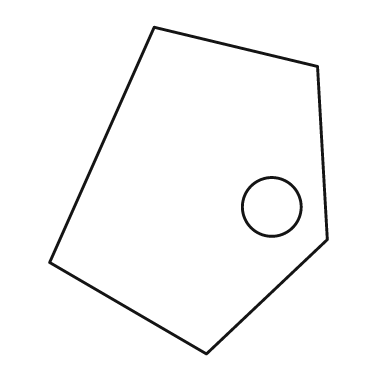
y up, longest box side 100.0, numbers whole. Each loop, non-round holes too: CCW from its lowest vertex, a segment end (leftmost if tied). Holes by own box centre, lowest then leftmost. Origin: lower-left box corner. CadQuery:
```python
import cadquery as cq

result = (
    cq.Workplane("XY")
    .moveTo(48.0, 0.0)
    .lineTo(85.0, 35.0)
    .lineTo(82.0, 88.0)
    .lineTo(32.0, 100.0)
    .lineTo(0.0, 28.0)
    .close()
    .moveTo(68.0, 45.0)
    .circle(9.0)
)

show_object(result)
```